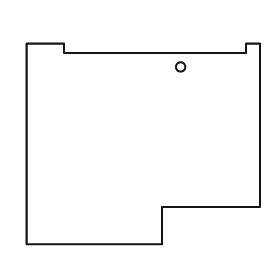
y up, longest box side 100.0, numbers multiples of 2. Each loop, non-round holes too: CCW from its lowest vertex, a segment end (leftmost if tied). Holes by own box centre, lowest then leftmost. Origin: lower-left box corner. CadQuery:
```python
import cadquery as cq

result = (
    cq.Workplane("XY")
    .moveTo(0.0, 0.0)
    .lineTo(58.0, 0.0)
    .lineTo(58.0, 16.0)
    .lineTo(100.0, 16.0)
    .lineTo(100.0, 86.0)
    .lineTo(94.0, 86.0)
    .lineTo(94.0, 82.0)
    .lineTo(16.0, 82.0)
    .lineTo(16.0, 86.0)
    .lineTo(0.0, 86.0)
    .close()
    .moveTo(66.0, 76.0)
    .circle(2.0)
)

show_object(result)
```